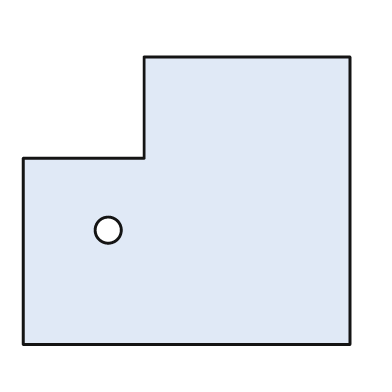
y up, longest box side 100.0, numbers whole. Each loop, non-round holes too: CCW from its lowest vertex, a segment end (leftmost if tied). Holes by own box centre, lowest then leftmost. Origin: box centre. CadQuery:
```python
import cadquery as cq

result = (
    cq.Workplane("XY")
    .moveTo(-50.0, -44.0)
    .lineTo(50.0, -44.0)
    .lineTo(50.0, 44.0)
    .lineTo(-13.0, 44.0)
    .lineTo(-13.0, 13.0)
    .lineTo(-50.0, 13.0)
    .close()
    .moveTo(-24.0, -9.0)
    .circle(4.0)
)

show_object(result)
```